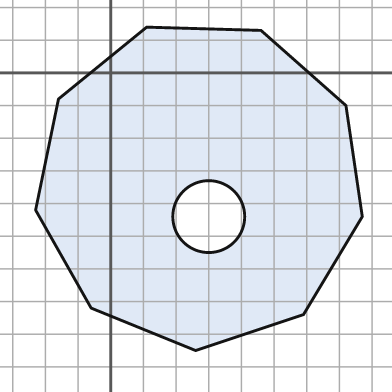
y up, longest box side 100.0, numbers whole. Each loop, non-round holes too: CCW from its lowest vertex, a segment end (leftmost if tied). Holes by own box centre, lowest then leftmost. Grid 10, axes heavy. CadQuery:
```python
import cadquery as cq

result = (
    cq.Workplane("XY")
    .moveTo(26.0, -85.0)
    .lineTo(59.0, -74.0)
    .lineTo(77.0, -44.0)
    .lineTo(72.0, -10.0)
    .lineTo(46.0, 13.0)
    .lineTo(11.0, 14.0)
    .lineTo(-16.0, -8.0)
    .lineTo(-23.0, -42.0)
    .lineTo(-6.0, -72.0)
    .close()
    .moveTo(30.0, -44.0)
    .circle(11.0)
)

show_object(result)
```